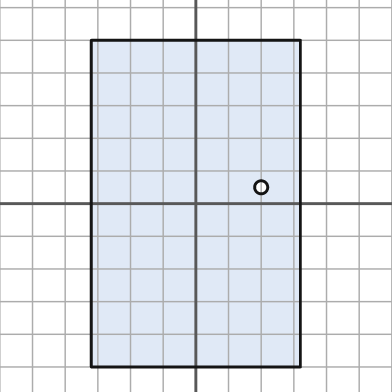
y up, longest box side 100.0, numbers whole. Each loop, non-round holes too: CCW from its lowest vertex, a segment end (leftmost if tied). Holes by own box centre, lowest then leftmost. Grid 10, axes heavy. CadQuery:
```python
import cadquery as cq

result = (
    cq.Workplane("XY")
    .moveTo(-32.0, -50.0)
    .lineTo(32.0, -50.0)
    .lineTo(32.0, 50.0)
    .lineTo(-32.0, 50.0)
    .close()
    .moveTo(20.0, 5.0)
    .circle(2.0)
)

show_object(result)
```